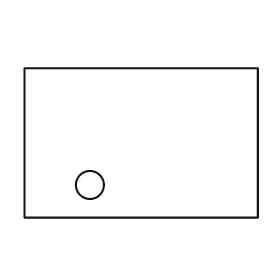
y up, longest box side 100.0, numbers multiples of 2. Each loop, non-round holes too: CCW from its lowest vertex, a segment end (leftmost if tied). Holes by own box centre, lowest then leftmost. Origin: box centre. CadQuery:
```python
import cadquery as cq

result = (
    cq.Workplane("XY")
    .moveTo(-50.0, -32.0)
    .lineTo(50.0, -32.0)
    .lineTo(50.0, 32.0)
    .lineTo(-50.0, 32.0)
    .close()
    .moveTo(-22.0, -18.0)
    .circle(6.0)
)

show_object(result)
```